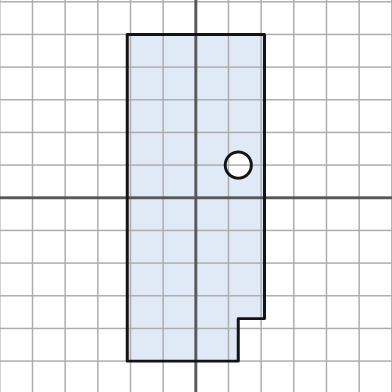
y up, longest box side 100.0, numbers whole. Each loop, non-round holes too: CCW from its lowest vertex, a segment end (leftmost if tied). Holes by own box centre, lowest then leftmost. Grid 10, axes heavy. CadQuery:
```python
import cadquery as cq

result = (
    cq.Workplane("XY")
    .moveTo(-21.0, -50.0)
    .lineTo(13.0, -50.0)
    .lineTo(13.0, -37.0)
    .lineTo(21.0, -37.0)
    .lineTo(21.0, 50.0)
    .lineTo(-21.0, 50.0)
    .close()
    .moveTo(13.0, 10.0)
    .circle(4.0)
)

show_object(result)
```